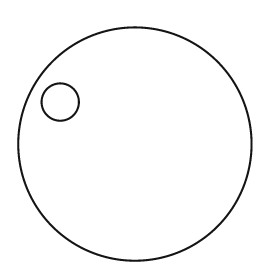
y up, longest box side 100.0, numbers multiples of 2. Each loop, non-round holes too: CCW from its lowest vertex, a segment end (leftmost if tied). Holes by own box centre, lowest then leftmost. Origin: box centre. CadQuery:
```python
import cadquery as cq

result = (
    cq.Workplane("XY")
    .moveTo(0.0, 0.0)
    .circle(50.0)
    .moveTo(-32.0, 18.0)
    .circle(8.0)
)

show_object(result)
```